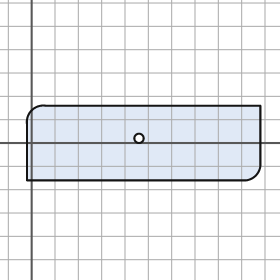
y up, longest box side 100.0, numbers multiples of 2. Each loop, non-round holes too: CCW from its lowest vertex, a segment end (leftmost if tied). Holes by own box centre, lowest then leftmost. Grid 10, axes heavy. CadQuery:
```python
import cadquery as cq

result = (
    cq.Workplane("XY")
    .moveTo(-2.0, -16.0)
    .lineTo(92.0, -16.0)
    .threePointArc((96.0, -14.0), (98.0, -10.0))
    .lineTo(98.0, 16.0)
    .lineTo(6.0, 16.0)
    .threePointArc((0.0, 14.0), (-2.0, 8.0))
    .close()
    .moveTo(46.0, 2.0)
    .circle(2.0)
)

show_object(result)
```